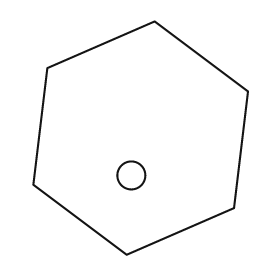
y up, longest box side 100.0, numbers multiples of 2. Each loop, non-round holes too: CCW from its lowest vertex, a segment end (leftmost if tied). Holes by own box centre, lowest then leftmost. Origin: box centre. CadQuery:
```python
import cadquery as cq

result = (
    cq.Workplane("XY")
    .moveTo(-6.0, -50.0)
    .lineTo(40.0, -30.0)
    .lineTo(46.0, 20.0)
    .lineTo(6.0, 50.0)
    .lineTo(-40.0, 30.0)
    .lineTo(-46.0, -20.0)
    .close()
    .moveTo(-4.0, -16.0)
    .circle(6.0)
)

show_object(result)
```